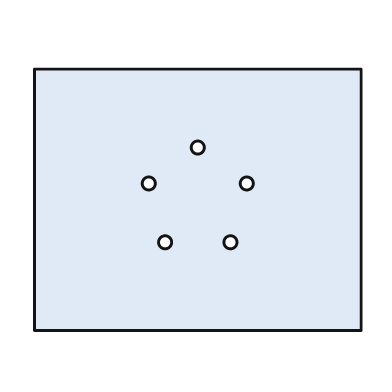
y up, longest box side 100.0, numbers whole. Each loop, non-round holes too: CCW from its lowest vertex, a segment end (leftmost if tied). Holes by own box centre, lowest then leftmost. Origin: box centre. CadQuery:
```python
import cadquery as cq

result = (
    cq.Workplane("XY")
    .moveTo(-50.0, -40.0)
    .lineTo(50.0, -40.0)
    .lineTo(50.0, 40.0)
    .lineTo(-50.0, 40.0)
    .close()
    .moveTo(-10.0, -13.0)
    .circle(2.0)
    .moveTo(10.0, -13.0)
    .circle(2.0)
    .moveTo(-15.0, 5.0)
    .circle(2.0)
    .moveTo(15.0, 5.0)
    .circle(2.0)
    .moveTo(0.0, 16.0)
    .circle(2.0)
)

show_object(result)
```